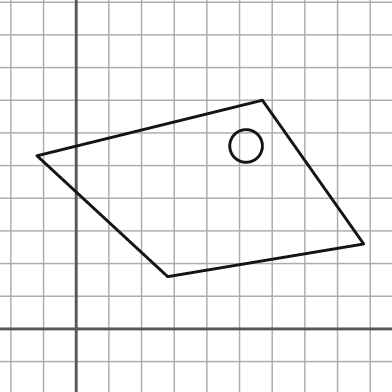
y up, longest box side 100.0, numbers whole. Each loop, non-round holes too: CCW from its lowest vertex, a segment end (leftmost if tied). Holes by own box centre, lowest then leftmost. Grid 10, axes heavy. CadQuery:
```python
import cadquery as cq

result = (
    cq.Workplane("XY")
    .moveTo(28.0, 16.0)
    .lineTo(88.0, 26.0)
    .lineTo(57.0, 70.0)
    .lineTo(-12.0, 53.0)
    .close()
    .moveTo(52.0, 56.0)
    .circle(5.0)
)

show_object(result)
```